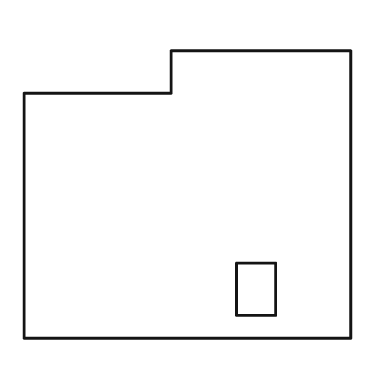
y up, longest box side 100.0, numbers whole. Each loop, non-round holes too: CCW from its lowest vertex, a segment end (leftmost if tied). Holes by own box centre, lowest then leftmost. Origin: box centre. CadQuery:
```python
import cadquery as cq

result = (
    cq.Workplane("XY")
    .moveTo(-50.0, -44.0)
    .lineTo(50.0, -44.0)
    .lineTo(50.0, 44.0)
    .lineTo(-5.0, 44.0)
    .lineTo(-5.0, 31.0)
    .lineTo(-50.0, 31.0)
    .close()
    .moveTo(15.0, -37.0)
    .lineTo(27.0, -37.0)
    .lineTo(27.0, -21.0)
    .lineTo(15.0, -21.0)
    .close()
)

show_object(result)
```